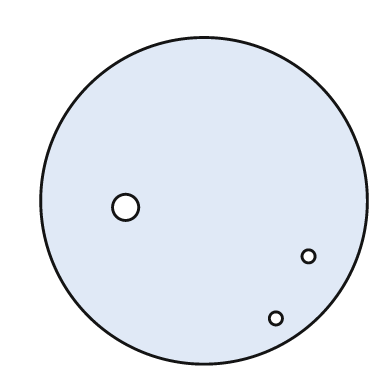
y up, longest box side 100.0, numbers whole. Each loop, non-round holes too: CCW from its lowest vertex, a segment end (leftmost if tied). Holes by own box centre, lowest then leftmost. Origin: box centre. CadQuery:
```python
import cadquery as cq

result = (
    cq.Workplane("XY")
    .moveTo(0.0, 0.0)
    .circle(50.0)
    .moveTo(22.0, -36.0)
    .circle(2.0)
    .moveTo(32.0, -17.0)
    .circle(2.0)
    .moveTo(-24.0, -2.0)
    .circle(4.0)
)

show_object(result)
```